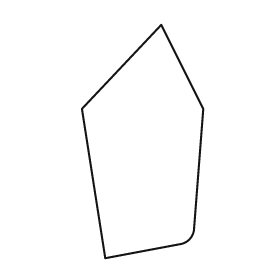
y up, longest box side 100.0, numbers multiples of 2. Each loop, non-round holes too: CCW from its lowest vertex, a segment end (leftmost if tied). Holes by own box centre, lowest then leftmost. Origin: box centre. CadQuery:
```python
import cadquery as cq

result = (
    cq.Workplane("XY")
    .moveTo(-16.0, -50.0)
    .lineTo(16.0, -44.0)
    .threePointArc((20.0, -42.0), (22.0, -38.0))
    .lineTo(26.0, 14.0)
    .lineTo(8.0, 50.0)
    .lineTo(-26.0, 14.0)
    .close()
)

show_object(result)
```